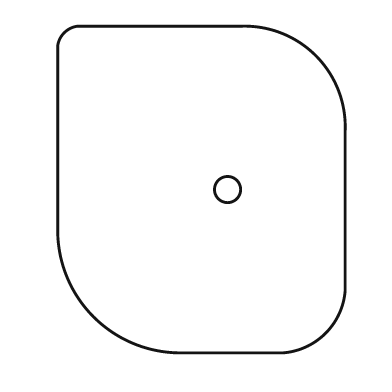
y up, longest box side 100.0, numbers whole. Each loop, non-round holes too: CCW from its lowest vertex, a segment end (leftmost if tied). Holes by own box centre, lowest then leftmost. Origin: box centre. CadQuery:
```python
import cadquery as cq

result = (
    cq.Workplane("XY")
    .moveTo(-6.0, -50.0)
    .lineTo(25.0, -50.0)
    .threePointArc((38.0, -44.0), (44.0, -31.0))
    .lineTo(44.0, 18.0)
    .threePointArc((35.0, 41.0), (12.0, 50.0))
    .lineTo(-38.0, 50.0)
    .threePointArc((-42.0, 48.0), (-44.0, 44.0))
    .lineTo(-44.0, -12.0)
    .threePointArc((-33.0, -39.0), (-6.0, -50.0))
    .close()
    .moveTo(8.0, 0.0)
    .circle(4.0)
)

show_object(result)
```